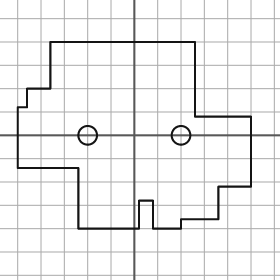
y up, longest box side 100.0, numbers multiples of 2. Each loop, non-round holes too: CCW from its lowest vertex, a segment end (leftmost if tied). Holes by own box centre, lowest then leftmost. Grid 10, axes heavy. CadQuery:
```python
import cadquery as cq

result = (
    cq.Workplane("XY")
    .moveTo(-24.0, -40.0)
    .lineTo(2.0, -40.0)
    .lineTo(2.0, -28.0)
    .lineTo(8.0, -28.0)
    .lineTo(8.0, -40.0)
    .lineTo(20.0, -40.0)
    .lineTo(20.0, -36.0)
    .lineTo(36.0, -36.0)
    .lineTo(36.0, -22.0)
    .lineTo(50.0, -22.0)
    .lineTo(50.0, 8.0)
    .lineTo(26.0, 8.0)
    .lineTo(26.0, 40.0)
    .lineTo(-36.0, 40.0)
    .lineTo(-36.0, 20.0)
    .lineTo(-46.0, 20.0)
    .lineTo(-46.0, 12.0)
    .lineTo(-50.0, 12.0)
    .lineTo(-50.0, -14.0)
    .lineTo(-24.0, -14.0)
    .close()
    .moveTo(-20.0, 0.0)
    .circle(4.0)
    .moveTo(20.0, 0.0)
    .circle(4.0)
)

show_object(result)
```